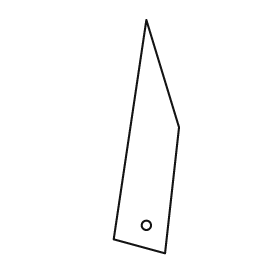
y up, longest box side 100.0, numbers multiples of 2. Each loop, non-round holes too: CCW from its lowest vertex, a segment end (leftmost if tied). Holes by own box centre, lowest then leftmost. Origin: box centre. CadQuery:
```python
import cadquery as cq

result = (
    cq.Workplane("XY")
    .moveTo(8.0, -50.0)
    .lineTo(14.0, 4.0)
    .lineTo(0.0, 50.0)
    .lineTo(-14.0, -44.0)
    .close()
    .moveTo(0.0, -38.0)
    .circle(2.0)
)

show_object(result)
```